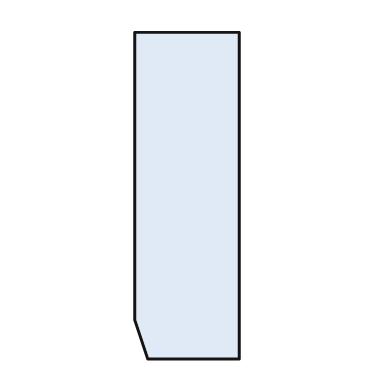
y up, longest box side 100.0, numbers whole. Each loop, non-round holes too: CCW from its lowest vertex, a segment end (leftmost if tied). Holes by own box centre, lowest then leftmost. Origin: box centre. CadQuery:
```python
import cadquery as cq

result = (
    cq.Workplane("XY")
    .moveTo(-12.0, -50.0)
    .lineTo(16.0, -50.0)
    .lineTo(16.0, 50.0)
    .lineTo(-16.0, 50.0)
    .lineTo(-16.0, -38.0)
    .close()
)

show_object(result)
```